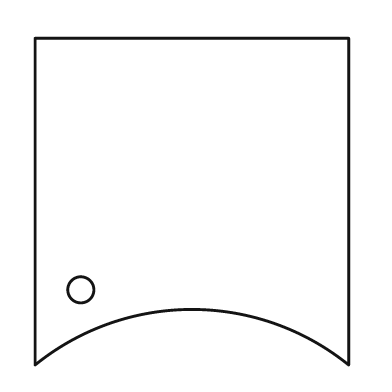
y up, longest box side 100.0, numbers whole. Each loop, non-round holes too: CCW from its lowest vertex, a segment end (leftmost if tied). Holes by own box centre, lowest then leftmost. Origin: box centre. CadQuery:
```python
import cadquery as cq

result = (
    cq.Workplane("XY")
    .moveTo(-48.0, -50.0)
    .threePointArc((0.0, -33.0), (48.0, -50.0))
    .lineTo(48.0, 50.0)
    .lineTo(-48.0, 50.0)
    .close()
    .moveTo(-34.0, -27.0)
    .circle(4.0)
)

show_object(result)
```